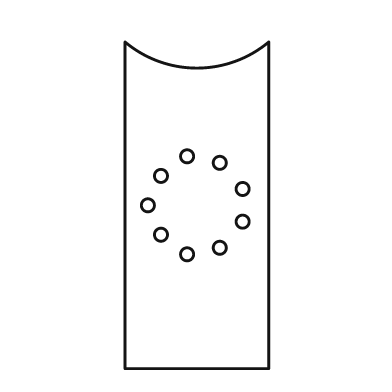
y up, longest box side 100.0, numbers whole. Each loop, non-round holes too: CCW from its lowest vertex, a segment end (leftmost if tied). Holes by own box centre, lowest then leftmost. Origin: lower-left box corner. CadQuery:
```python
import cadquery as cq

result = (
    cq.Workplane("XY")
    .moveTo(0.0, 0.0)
    .lineTo(44.0, 0.0)
    .lineTo(44.0, 100.0)
    .threePointArc((22.0, 92.0), (0.0, 100.0))
    .close()
    .moveTo(19.0, 35.0)
    .circle(2.0)
    .moveTo(29.0, 37.0)
    .circle(2.0)
    .moveTo(11.0, 41.0)
    .circle(2.0)
    .moveTo(36.0, 45.0)
    .circle(2.0)
    .moveTo(7.0, 50.0)
    .circle(2.0)
    .moveTo(36.0, 55.0)
    .circle(2.0)
    .moveTo(11.0, 59.0)
    .circle(2.0)
    .moveTo(29.0, 63.0)
    .circle(2.0)
    .moveTo(19.0, 65.0)
    .circle(2.0)
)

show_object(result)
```